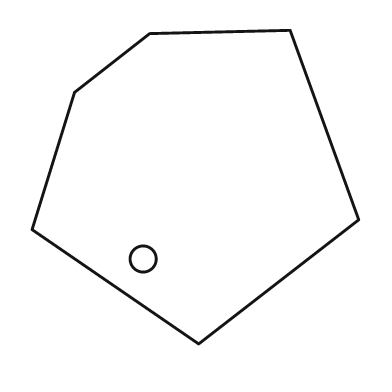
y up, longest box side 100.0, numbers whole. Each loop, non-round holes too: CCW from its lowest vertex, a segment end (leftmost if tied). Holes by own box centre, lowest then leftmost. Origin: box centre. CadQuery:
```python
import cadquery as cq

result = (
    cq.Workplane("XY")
    .moveTo(1.0, -48.0)
    .lineTo(50.0, -10.0)
    .lineTo(29.0, 48.0)
    .lineTo(-14.0, 47.0)
    .lineTo(-37.0, 29.0)
    .lineTo(-50.0, -13.0)
    .close()
    .moveTo(-16.0, -22.0)
    .circle(4.0)
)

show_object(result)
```